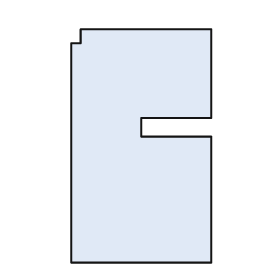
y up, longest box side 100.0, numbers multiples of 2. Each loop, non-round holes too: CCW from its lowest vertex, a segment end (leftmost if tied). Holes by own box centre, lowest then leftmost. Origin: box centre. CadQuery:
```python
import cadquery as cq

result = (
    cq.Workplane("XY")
    .moveTo(-30.0, -50.0)
    .lineTo(30.0, -50.0)
    .lineTo(30.0, 4.0)
    .lineTo(0.0, 4.0)
    .lineTo(0.0, 12.0)
    .lineTo(30.0, 12.0)
    .lineTo(30.0, 50.0)
    .lineTo(-26.0, 50.0)
    .lineTo(-26.0, 44.0)
    .lineTo(-30.0, 44.0)
    .close()
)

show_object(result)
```